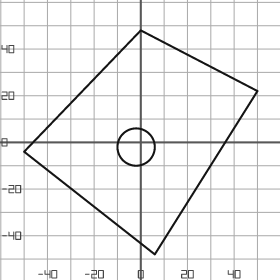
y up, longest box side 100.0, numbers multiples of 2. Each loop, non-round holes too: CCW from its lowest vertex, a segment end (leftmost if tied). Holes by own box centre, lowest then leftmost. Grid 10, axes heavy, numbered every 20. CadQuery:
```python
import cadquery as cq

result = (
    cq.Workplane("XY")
    .moveTo(6.0, -48.0)
    .lineTo(50.0, 22.0)
    .lineTo(0.0, 48.0)
    .lineTo(-50.0, -4.0)
    .close()
    .moveTo(-2.0, -2.0)
    .circle(8.0)
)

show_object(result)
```